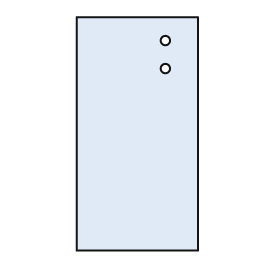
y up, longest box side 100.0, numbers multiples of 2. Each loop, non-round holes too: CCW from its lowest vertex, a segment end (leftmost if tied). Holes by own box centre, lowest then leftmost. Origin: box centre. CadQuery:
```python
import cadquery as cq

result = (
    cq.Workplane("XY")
    .moveTo(-26.0, -50.0)
    .lineTo(26.0, -50.0)
    .lineTo(26.0, 50.0)
    .lineTo(-26.0, 50.0)
    .close()
    .moveTo(12.0, 28.0)
    .circle(2.0)
    .moveTo(12.0, 40.0)
    .circle(2.0)
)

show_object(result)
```